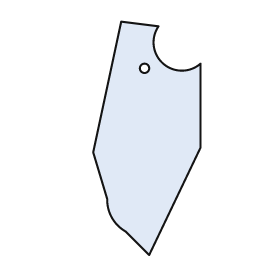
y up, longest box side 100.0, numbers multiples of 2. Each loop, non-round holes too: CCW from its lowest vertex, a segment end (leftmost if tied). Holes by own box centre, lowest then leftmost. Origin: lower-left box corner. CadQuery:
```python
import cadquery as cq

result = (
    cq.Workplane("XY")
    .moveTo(24.0, 0.0)
    .lineTo(46.0, 46.0)
    .lineTo(46.0, 82.0)
    .threePointArc((30.0, 82.0), (28.0, 98.0))
    .lineTo(12.0, 100.0)
    .lineTo(0.0, 44.0)
    .lineTo(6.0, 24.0)
    .threePointArc((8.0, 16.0), (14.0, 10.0))
    .close()
    .moveTo(22.0, 80.0)
    .circle(2.0)
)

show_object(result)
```